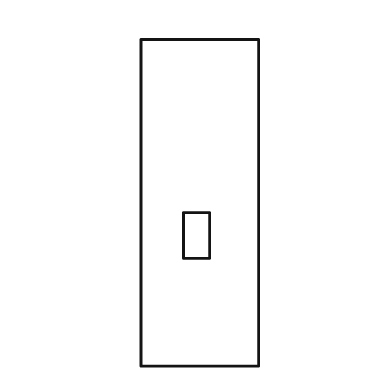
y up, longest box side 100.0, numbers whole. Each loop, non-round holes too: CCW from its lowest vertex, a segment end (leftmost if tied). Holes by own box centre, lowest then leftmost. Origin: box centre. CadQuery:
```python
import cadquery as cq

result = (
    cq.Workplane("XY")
    .moveTo(-18.0, -50.0)
    .lineTo(18.0, -50.0)
    .lineTo(18.0, 50.0)
    .lineTo(-18.0, 50.0)
    .close()
    .moveTo(-5.0, -17.0)
    .lineTo(3.0, -17.0)
    .lineTo(3.0, -3.0)
    .lineTo(-5.0, -3.0)
    .close()
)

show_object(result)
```